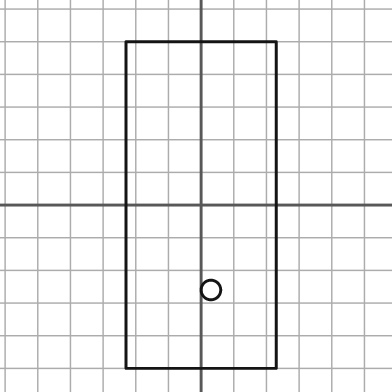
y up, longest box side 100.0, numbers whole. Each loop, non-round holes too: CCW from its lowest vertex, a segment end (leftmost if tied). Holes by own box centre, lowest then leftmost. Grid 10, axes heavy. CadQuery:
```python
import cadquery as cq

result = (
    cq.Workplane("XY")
    .moveTo(-23.0, -50.0)
    .lineTo(23.0, -50.0)
    .lineTo(23.0, 50.0)
    .lineTo(-23.0, 50.0)
    .close()
    .moveTo(3.0, -26.0)
    .circle(3.0)
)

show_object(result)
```